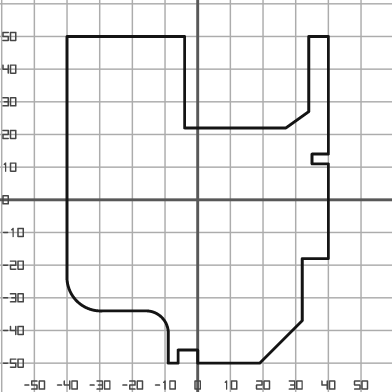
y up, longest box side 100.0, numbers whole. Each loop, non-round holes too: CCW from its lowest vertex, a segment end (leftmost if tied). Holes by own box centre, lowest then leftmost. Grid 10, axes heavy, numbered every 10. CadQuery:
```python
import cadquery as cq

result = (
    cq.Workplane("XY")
    .moveTo(-9.0, -50.0)
    .lineTo(-6.0, -50.0)
    .lineTo(-6.0, -46.0)
    .lineTo(0.0, -46.0)
    .lineTo(0.0, -50.0)
    .lineTo(19.0, -50.0)
    .lineTo(32.0, -37.0)
    .lineTo(32.0, -18.0)
    .lineTo(40.0, -18.0)
    .lineTo(40.0, 11.0)
    .lineTo(35.0, 11.0)
    .lineTo(35.0, 14.0)
    .lineTo(40.0, 14.0)
    .lineTo(40.0, 50.0)
    .lineTo(34.0, 50.0)
    .lineTo(34.0, 27.0)
    .lineTo(27.0, 22.0)
    .lineTo(-4.0, 22.0)
    .lineTo(-4.0, 50.0)
    .lineTo(-40.0, 50.0)
    .lineTo(-40.0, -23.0)
    .threePointArc((-37.0, -31.0), (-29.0, -34.0))
    .lineTo(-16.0, -34.0)
    .threePointArc((-11.0, -36.0), (-9.0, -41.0))
    .close()
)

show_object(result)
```